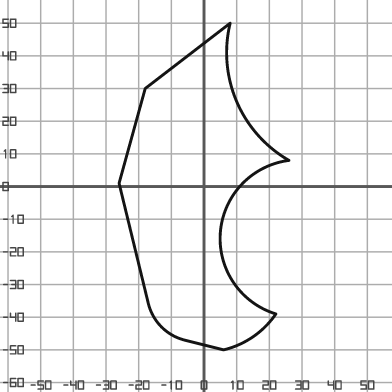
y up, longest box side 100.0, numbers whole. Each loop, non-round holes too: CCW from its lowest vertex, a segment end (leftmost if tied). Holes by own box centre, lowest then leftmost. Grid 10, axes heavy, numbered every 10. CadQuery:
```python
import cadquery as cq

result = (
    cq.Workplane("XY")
    .moveTo(6.0, -50.0)
    .threePointArc((15.0, -46.0), (22.0, -39.0))
    .threePointArc((5.0, -14.0), (26.0, 8.0))
    .threePointArc((10.0, 26.0), (8.0, 50.0))
    .lineTo(-18.0, 30.0)
    .lineTo(-26.0, 1.0)
    .lineTo(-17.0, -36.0)
    .threePointArc((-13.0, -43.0), (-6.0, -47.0))
    .close()
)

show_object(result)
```